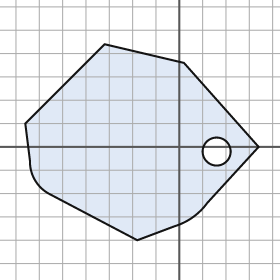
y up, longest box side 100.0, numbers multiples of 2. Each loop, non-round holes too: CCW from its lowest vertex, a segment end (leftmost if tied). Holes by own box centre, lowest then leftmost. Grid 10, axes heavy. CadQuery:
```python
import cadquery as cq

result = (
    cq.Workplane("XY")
    .moveTo(-18.0, -40.0)
    .lineTo(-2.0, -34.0)
    .threePointArc((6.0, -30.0), (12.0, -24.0))
    .lineTo(34.0, 0.0)
    .lineTo(2.0, 36.0)
    .lineTo(-32.0, 44.0)
    .lineTo(-66.0, 10.0)
    .lineTo(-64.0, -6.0)
    .threePointArc((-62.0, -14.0), (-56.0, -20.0))
    .close()
    .moveTo(16.0, -2.0)
    .circle(6.0)
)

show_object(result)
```